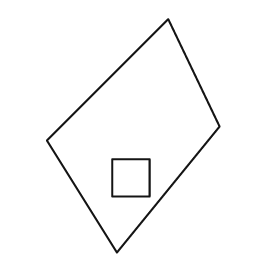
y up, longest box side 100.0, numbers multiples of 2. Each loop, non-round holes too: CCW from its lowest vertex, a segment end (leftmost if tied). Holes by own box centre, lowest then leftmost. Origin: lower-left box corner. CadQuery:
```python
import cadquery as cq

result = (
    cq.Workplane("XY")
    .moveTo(30.0, 0.0)
    .lineTo(74.0, 54.0)
    .lineTo(52.0, 100.0)
    .lineTo(0.0, 48.0)
    .close()
    .moveTo(28.0, 24.0)
    .lineTo(44.0, 24.0)
    .lineTo(44.0, 40.0)
    .lineTo(28.0, 40.0)
    .close()
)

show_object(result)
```